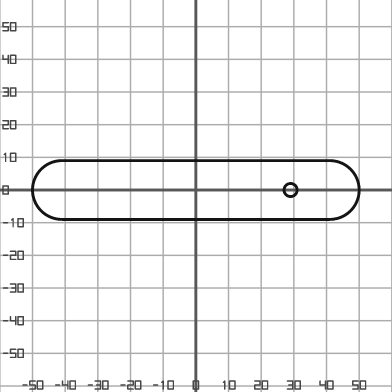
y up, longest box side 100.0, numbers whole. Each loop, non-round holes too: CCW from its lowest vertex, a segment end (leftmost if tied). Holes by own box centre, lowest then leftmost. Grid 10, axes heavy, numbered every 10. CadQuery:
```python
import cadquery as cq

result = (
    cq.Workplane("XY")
    .moveTo(-41.0, -9.0)
    .lineTo(41.0, -9.0)
    .threePointArc((50.0, 0.0), (41.0, 9.0))
    .lineTo(-41.0, 9.0)
    .threePointArc((-50.0, 0.0), (-41.0, -9.0))
    .close()
    .moveTo(29.0, 0.0)
    .circle(2.0)
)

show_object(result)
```